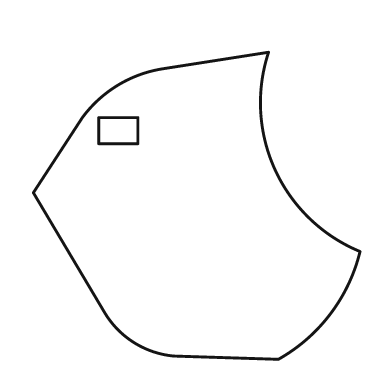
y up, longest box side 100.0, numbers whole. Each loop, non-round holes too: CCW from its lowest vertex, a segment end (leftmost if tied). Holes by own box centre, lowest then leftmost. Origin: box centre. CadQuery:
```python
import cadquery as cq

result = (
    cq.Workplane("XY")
    .moveTo(25.0, -47.0)
    .threePointArc((41.0, -33.0), (50.0, -14.0))
    .threePointArc((24.0, 11.0), (22.0, 47.0))
    .lineTo(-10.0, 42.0)
    .threePointArc((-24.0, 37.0), (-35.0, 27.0))
    .lineTo(-50.0, 4.0)
    .lineTo(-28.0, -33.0)
    .threePointArc((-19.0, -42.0), (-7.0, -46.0))
    .close()
    .moveTo(-30.0, 19.0)
    .lineTo(-18.0, 19.0)
    .lineTo(-18.0, 27.0)
    .lineTo(-30.0, 27.0)
    .close()
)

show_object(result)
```